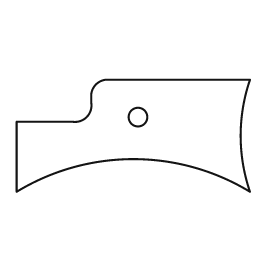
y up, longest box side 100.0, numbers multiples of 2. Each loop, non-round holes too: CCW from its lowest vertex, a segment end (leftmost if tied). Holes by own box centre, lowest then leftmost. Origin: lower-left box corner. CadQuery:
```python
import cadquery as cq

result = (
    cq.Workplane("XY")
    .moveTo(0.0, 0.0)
    .threePointArc((50.0, 14.0), (100.0, 0.0))
    .threePointArc((96.0, 24.0), (100.0, 48.0))
    .lineTo(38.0, 48.0)
    .threePointArc((34.0, 46.0), (32.0, 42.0))
    .lineTo(32.0, 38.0)
    .threePointArc((30.0, 32.0), (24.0, 30.0))
    .lineTo(0.0, 30.0)
    .close()
    .moveTo(52.0, 32.0)
    .circle(4.0)
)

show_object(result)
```